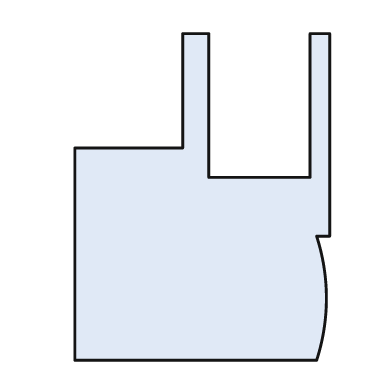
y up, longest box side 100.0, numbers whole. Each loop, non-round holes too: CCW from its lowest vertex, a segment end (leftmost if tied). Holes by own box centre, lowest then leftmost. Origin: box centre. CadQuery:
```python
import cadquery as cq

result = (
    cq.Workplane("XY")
    .moveTo(-39.0, -50.0)
    .lineTo(35.0, -50.0)
    .threePointArc((38.0, -31.0), (35.0, -12.0))
    .lineTo(39.0, -12.0)
    .lineTo(39.0, 50.0)
    .lineTo(33.0, 50.0)
    .lineTo(33.0, 6.0)
    .lineTo(2.0, 6.0)
    .lineTo(2.0, 50.0)
    .lineTo(-6.0, 50.0)
    .lineTo(-6.0, 15.0)
    .lineTo(-39.0, 15.0)
    .close()
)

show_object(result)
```